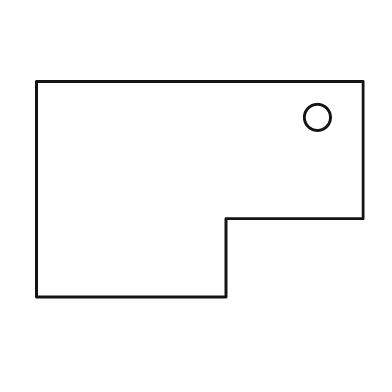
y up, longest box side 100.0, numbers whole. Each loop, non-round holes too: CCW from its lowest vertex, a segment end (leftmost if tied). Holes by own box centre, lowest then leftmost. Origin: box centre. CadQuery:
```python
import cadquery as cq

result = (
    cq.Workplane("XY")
    .moveTo(-50.0, -33.0)
    .lineTo(8.0, -33.0)
    .lineTo(8.0, -9.0)
    .lineTo(50.0, -9.0)
    .lineTo(50.0, 33.0)
    .lineTo(-50.0, 33.0)
    .close()
    .moveTo(36.0, 22.0)
    .circle(4.0)
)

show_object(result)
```